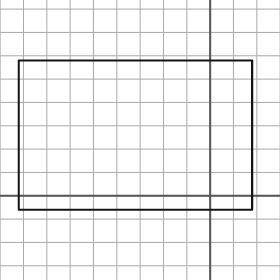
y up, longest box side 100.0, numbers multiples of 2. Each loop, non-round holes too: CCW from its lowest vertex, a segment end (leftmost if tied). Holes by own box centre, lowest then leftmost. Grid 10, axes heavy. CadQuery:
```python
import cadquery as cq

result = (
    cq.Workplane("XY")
    .moveTo(-82.0, -6.0)
    .lineTo(18.0, -6.0)
    .lineTo(18.0, 58.0)
    .lineTo(-82.0, 58.0)
    .close()
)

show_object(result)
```